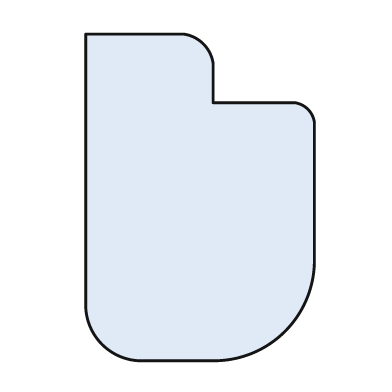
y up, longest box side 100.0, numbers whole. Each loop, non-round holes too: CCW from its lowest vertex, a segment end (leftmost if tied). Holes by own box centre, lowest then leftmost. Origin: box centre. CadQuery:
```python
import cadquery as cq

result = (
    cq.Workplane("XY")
    .moveTo(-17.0, -50.0)
    .lineTo(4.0, -50.0)
    .threePointArc((26.0, -41.0), (35.0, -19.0))
    .lineTo(35.0, 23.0)
    .threePointArc((33.0, 27.0), (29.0, 29.0))
    .lineTo(4.0, 29.0)
    .lineTo(4.0, 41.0)
    .threePointArc((1.0, 47.0), (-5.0, 50.0))
    .lineTo(-35.0, 50.0)
    .lineTo(-35.0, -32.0)
    .threePointArc((-30.0, -45.0), (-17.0, -50.0))
    .close()
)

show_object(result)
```